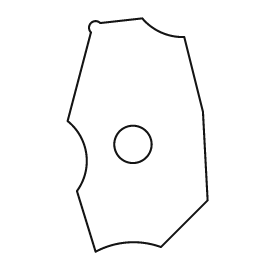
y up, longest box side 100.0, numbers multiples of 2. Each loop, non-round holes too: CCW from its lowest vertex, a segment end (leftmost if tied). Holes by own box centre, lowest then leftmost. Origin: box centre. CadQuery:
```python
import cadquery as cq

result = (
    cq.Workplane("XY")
    .moveTo(-18.0, -50.0)
    .threePointArc((-4.0, -46.0), (10.0, -48.0))
    .lineTo(30.0, -28.0)
    .lineTo(28.0, 10.0)
    .lineTo(20.0, 42.0)
    .threePointArc((10.0, 44.0), (2.0, 50.0))
    .lineTo(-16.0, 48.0)
    .threePointArc((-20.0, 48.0), (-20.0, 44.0))
    .lineTo(-30.0, 6.0)
    .threePointArc((-22.0, -8.0), (-26.0, -24.0))
    .close()
    .moveTo(-2.0, -4.0)
    .circle(8.0)
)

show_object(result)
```